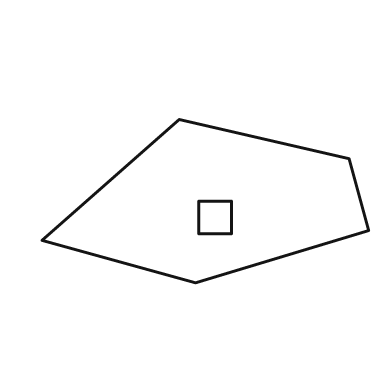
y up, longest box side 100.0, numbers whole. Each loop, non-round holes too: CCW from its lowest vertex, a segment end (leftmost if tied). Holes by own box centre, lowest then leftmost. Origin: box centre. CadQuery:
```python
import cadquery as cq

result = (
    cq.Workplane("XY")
    .moveTo(-3.0, -25.0)
    .lineTo(50.0, -9.0)
    .lineTo(44.0, 13.0)
    .lineTo(-8.0, 25.0)
    .lineTo(-50.0, -12.0)
    .close()
    .moveTo(-2.0, -10.0)
    .lineTo(8.0, -10.0)
    .lineTo(8.0, 0.0)
    .lineTo(-2.0, 0.0)
    .close()
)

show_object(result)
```